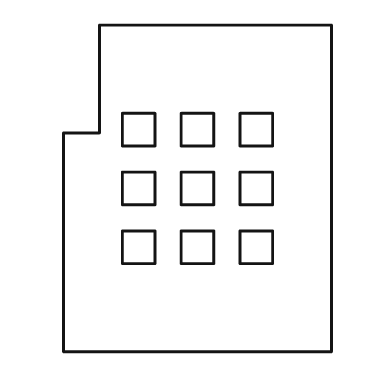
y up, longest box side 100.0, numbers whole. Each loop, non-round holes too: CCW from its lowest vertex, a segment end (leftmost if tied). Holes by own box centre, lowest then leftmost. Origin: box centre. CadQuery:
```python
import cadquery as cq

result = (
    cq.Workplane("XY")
    .moveTo(-41.0, -50.0)
    .lineTo(41.0, -50.0)
    .lineTo(41.0, 50.0)
    .lineTo(-30.0, 50.0)
    .lineTo(-30.0, 17.0)
    .lineTo(-41.0, 17.0)
    .close()
    .moveTo(-23.0, -23.0)
    .lineTo(-13.0, -23.0)
    .lineTo(-13.0, -13.0)
    .lineTo(-23.0, -13.0)
    .close()
    .moveTo(-5.0, -23.0)
    .lineTo(5.0, -23.0)
    .lineTo(5.0, -13.0)
    .lineTo(-5.0, -13.0)
    .close()
    .moveTo(13.0, -23.0)
    .lineTo(23.0, -23.0)
    .lineTo(23.0, -13.0)
    .lineTo(13.0, -13.0)
    .close()
    .moveTo(-23.0, -5.0)
    .lineTo(-13.0, -5.0)
    .lineTo(-13.0, 5.0)
    .lineTo(-23.0, 5.0)
    .close()
    .moveTo(-5.0, -5.0)
    .lineTo(5.0, -5.0)
    .lineTo(5.0, 5.0)
    .lineTo(-5.0, 5.0)
    .close()
    .moveTo(13.0, -5.0)
    .lineTo(23.0, -5.0)
    .lineTo(23.0, 5.0)
    .lineTo(13.0, 5.0)
    .close()
    .moveTo(-23.0, 13.0)
    .lineTo(-13.0, 13.0)
    .lineTo(-13.0, 23.0)
    .lineTo(-23.0, 23.0)
    .close()
    .moveTo(-5.0, 13.0)
    .lineTo(5.0, 13.0)
    .lineTo(5.0, 23.0)
    .lineTo(-5.0, 23.0)
    .close()
    .moveTo(13.0, 13.0)
    .lineTo(23.0, 13.0)
    .lineTo(23.0, 23.0)
    .lineTo(13.0, 23.0)
    .close()
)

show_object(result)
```